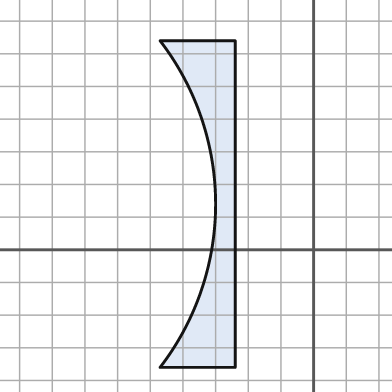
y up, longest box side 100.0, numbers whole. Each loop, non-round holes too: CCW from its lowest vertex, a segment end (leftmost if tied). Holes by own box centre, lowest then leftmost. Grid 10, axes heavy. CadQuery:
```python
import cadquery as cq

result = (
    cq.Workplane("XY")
    .moveTo(-47.0, -36.0)
    .lineTo(-24.0, -36.0)
    .lineTo(-24.0, 64.0)
    .lineTo(-47.0, 64.0)
    .threePointArc((-30.0, 14.0), (-47.0, -36.0))
    .close()
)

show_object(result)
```